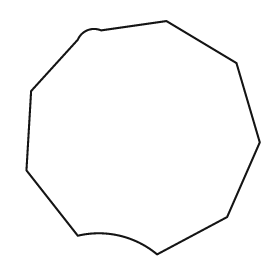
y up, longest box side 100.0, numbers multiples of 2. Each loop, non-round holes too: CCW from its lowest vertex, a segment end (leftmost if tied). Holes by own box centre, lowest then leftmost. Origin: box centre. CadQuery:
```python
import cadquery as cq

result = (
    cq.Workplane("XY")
    .moveTo(6.0, -50.0)
    .lineTo(36.0, -34.0)
    .lineTo(50.0, -2.0)
    .lineTo(40.0, 32.0)
    .lineTo(10.0, 50.0)
    .lineTo(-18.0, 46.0)
    .threePointArc((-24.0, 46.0), (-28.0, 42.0))
    .lineTo(-48.0, 20.0)
    .lineTo(-50.0, -14.0)
    .lineTo(-28.0, -42.0)
    .threePointArc((-10.0, -42.0), (6.0, -50.0))
    .close()
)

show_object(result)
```